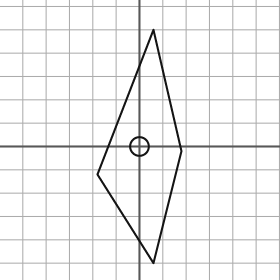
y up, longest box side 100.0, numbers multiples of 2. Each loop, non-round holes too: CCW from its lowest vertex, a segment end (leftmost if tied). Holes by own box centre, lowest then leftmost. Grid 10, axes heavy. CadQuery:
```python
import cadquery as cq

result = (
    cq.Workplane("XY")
    .moveTo(6.0, -50.0)
    .lineTo(18.0, -2.0)
    .lineTo(6.0, 50.0)
    .lineTo(-18.0, -12.0)
    .close()
    .moveTo(0.0, 0.0)
    .circle(4.0)
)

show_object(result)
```